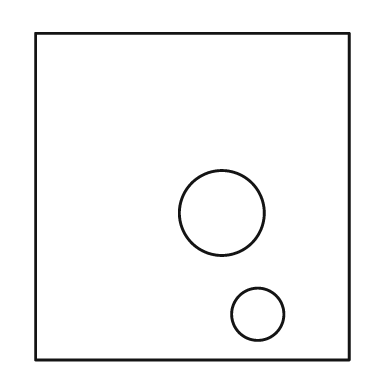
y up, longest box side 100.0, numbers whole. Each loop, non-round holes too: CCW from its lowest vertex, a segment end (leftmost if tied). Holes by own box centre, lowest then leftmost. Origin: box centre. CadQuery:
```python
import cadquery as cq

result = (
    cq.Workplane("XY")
    .moveTo(-48.0, -50.0)
    .lineTo(48.0, -50.0)
    .lineTo(48.0, 50.0)
    .lineTo(-48.0, 50.0)
    .close()
    .moveTo(20.0, -36.0)
    .circle(8.0)
    .moveTo(9.0, -5.0)
    .circle(13.0)
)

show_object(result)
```